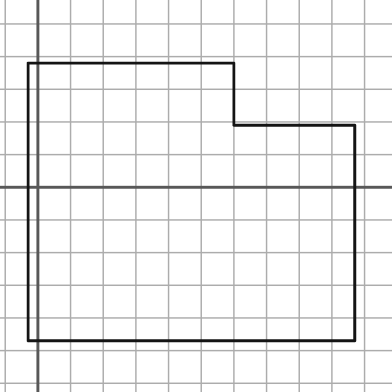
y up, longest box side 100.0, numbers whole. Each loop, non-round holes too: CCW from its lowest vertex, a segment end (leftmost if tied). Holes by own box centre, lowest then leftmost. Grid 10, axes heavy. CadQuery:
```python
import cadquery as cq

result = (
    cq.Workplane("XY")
    .moveTo(-3.0, -47.0)
    .lineTo(97.0, -47.0)
    .lineTo(97.0, 19.0)
    .lineTo(60.0, 19.0)
    .lineTo(60.0, 38.0)
    .lineTo(-3.0, 38.0)
    .close()
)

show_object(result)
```